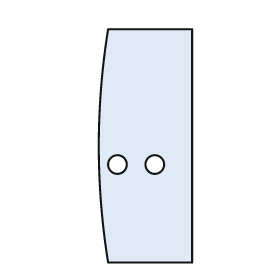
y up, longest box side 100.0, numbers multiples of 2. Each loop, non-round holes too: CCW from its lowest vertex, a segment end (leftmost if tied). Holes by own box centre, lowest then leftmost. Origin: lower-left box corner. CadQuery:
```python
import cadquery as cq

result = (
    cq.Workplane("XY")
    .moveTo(4.0, 0.0)
    .lineTo(40.0, 0.0)
    .lineTo(40.0, 100.0)
    .lineTo(4.0, 100.0)
    .threePointArc((0.0, 50.0), (4.0, 0.0))
    .close()
    .moveTo(8.0, 42.0)
    .circle(4.0)
    .moveTo(24.0, 42.0)
    .circle(4.0)
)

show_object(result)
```